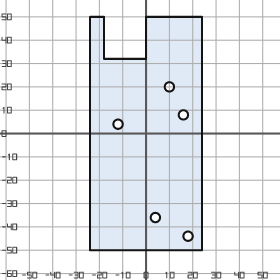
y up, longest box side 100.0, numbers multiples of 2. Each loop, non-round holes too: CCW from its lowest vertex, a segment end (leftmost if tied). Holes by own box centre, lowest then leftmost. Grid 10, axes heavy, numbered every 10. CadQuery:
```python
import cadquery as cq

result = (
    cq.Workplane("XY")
    .moveTo(-24.0, -50.0)
    .lineTo(24.0, -50.0)
    .lineTo(24.0, 50.0)
    .lineTo(0.0, 50.0)
    .lineTo(0.0, 32.0)
    .lineTo(-18.0, 32.0)
    .lineTo(-18.0, 50.0)
    .lineTo(-24.0, 50.0)
    .close()
    .moveTo(18.0, -44.0)
    .circle(2.0)
    .moveTo(4.0, -36.0)
    .circle(2.0)
    .moveTo(-12.0, 4.0)
    .circle(2.0)
    .moveTo(16.0, 8.0)
    .circle(2.0)
    .moveTo(10.0, 20.0)
    .circle(2.0)
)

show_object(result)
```